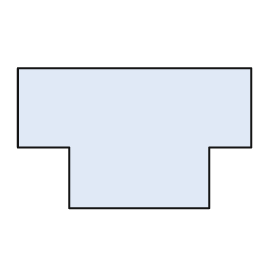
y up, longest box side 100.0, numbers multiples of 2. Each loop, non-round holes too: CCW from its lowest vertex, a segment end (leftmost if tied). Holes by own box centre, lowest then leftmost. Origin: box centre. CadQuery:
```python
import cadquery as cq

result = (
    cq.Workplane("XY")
    .moveTo(-28.0, -30.0)
    .lineTo(32.0, -30.0)
    .lineTo(32.0, -4.0)
    .lineTo(50.0, -4.0)
    .lineTo(50.0, 30.0)
    .lineTo(-50.0, 30.0)
    .lineTo(-50.0, -4.0)
    .lineTo(-28.0, -4.0)
    .close()
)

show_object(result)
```